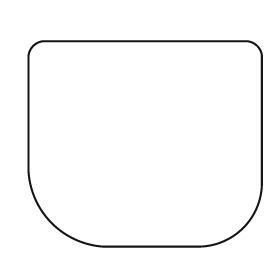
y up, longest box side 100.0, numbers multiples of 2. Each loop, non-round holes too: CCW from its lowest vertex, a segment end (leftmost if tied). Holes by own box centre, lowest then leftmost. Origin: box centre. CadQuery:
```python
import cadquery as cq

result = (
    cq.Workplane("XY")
    .moveTo(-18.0, -44.0)
    .lineTo(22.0, -44.0)
    .threePointArc((42.0, -36.0), (50.0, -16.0))
    .lineTo(50.0, 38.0)
    .threePointArc((48.0, 42.0), (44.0, 44.0))
    .lineTo(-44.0, 44.0)
    .threePointArc((-48.0, 42.0), (-50.0, 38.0))
    .lineTo(-50.0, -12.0)
    .threePointArc((-40.0, -34.0), (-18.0, -44.0))
    .close()
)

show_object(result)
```